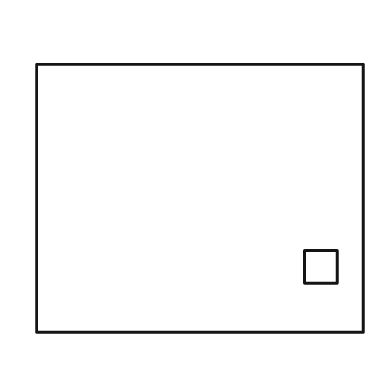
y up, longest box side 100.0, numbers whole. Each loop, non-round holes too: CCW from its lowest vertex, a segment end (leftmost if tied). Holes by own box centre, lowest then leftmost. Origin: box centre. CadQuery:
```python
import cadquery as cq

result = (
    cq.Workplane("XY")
    .moveTo(-50.0, -41.0)
    .lineTo(50.0, -41.0)
    .lineTo(50.0, 41.0)
    .lineTo(-50.0, 41.0)
    .close()
    .moveTo(32.0, -26.0)
    .lineTo(42.0, -26.0)
    .lineTo(42.0, -16.0)
    .lineTo(32.0, -16.0)
    .close()
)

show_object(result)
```